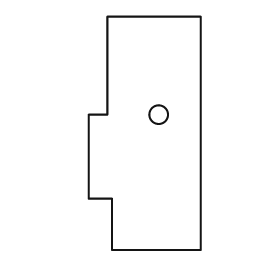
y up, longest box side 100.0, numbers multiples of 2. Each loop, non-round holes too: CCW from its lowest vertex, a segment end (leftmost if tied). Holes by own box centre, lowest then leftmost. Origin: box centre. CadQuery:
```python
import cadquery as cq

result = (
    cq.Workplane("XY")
    .moveTo(-14.0, -50.0)
    .lineTo(24.0, -50.0)
    .lineTo(24.0, 50.0)
    .lineTo(-16.0, 50.0)
    .lineTo(-16.0, 8.0)
    .lineTo(-24.0, 8.0)
    .lineTo(-24.0, -28.0)
    .lineTo(-14.0, -28.0)
    .close()
    .moveTo(6.0, 8.0)
    .circle(4.0)
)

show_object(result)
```